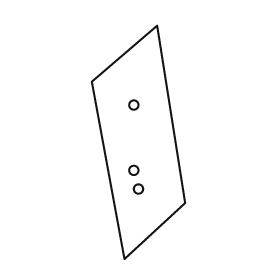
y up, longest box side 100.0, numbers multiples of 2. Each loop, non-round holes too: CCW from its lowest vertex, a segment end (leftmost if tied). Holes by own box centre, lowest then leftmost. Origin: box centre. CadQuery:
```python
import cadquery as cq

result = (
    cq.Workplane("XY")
    .moveTo(-6.0, -50.0)
    .lineTo(20.0, -26.0)
    .lineTo(8.0, 50.0)
    .lineTo(-20.0, 26.0)
    .close()
    .moveTo(0.0, -20.0)
    .circle(2.0)
    .moveTo(-2.0, -12.0)
    .circle(2.0)
    .moveTo(-2.0, 16.0)
    .circle(2.0)
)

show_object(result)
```